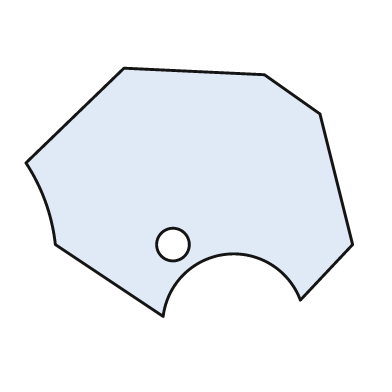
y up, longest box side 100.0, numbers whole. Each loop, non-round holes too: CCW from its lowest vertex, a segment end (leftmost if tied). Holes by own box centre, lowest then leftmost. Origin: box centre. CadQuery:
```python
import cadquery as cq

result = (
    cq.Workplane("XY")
    .moveTo(-8.0, -38.0)
    .threePointArc((11.0, -19.0), (34.0, -33.0))
    .lineTo(50.0, -16.0)
    .lineTo(40.0, 24.0)
    .lineTo(23.0, 36.0)
    .lineTo(-20.0, 38.0)
    .lineTo(-50.0, 9.0)
    .threePointArc((-44.0, -3.0), (-41.0, -16.0))
    .close()
    .moveTo(-5.0, -16.0)
    .circle(5.0)
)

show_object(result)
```